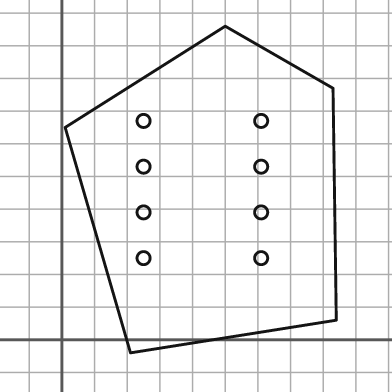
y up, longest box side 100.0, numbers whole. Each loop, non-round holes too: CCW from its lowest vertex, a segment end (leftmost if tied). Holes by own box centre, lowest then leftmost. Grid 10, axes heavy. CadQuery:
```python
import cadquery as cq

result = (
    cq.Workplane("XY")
    .moveTo(21.0, -4.0)
    .lineTo(84.0, 6.0)
    .lineTo(83.0, 77.0)
    .lineTo(50.0, 96.0)
    .lineTo(1.0, 65.0)
    .close()
    .moveTo(25.0, 25.0)
    .circle(2.0)
    .moveTo(61.0, 25.0)
    .circle(2.0)
    .moveTo(25.0, 39.0)
    .circle(2.0)
    .moveTo(61.0, 39.0)
    .circle(2.0)
    .moveTo(25.0, 53.0)
    .circle(2.0)
    .moveTo(61.0, 53.0)
    .circle(2.0)
    .moveTo(25.0, 67.0)
    .circle(2.0)
    .moveTo(61.0, 67.0)
    .circle(2.0)
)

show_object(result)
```